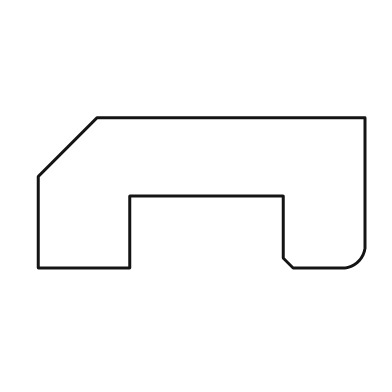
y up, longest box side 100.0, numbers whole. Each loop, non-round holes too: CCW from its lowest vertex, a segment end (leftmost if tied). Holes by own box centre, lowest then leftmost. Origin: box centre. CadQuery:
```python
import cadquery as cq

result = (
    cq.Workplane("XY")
    .moveTo(-50.0, -23.0)
    .lineTo(-22.0, -23.0)
    .lineTo(-22.0, -1.0)
    .lineTo(25.0, -1.0)
    .lineTo(25.0, -20.0)
    .lineTo(28.0, -23.0)
    .lineTo(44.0, -23.0)
    .threePointArc((48.0, -21.0), (50.0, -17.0))
    .lineTo(50.0, 23.0)
    .lineTo(-32.0, 23.0)
    .lineTo(-50.0, 5.0)
    .close()
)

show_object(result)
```